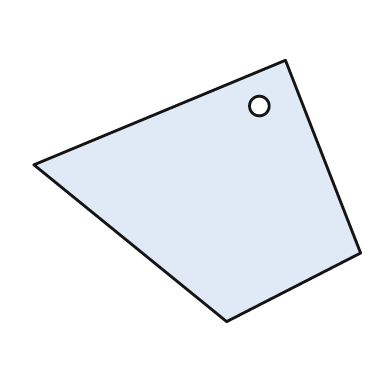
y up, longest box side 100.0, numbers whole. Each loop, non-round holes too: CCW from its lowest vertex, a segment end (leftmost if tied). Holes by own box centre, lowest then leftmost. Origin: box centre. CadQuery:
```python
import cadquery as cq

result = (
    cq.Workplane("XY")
    .moveTo(9.0, -40.0)
    .lineTo(50.0, -19.0)
    .lineTo(27.0, 40.0)
    .lineTo(-50.0, 8.0)
    .close()
    .moveTo(19.0, 26.0)
    .circle(3.0)
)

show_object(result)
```